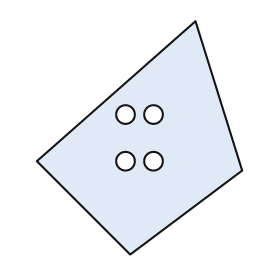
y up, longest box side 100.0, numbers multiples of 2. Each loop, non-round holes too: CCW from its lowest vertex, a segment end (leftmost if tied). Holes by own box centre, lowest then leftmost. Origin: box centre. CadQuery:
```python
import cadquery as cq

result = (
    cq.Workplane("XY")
    .moveTo(-4.0, -50.0)
    .lineTo(44.0, -14.0)
    .lineTo(24.0, 50.0)
    .lineTo(-44.0, -10.0)
    .close()
    .moveTo(-6.0, -10.0)
    .circle(4.0)
    .moveTo(6.0, -10.0)
    .circle(4.0)
    .moveTo(-6.0, 10.0)
    .circle(4.0)
    .moveTo(6.0, 10.0)
    .circle(4.0)
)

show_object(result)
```